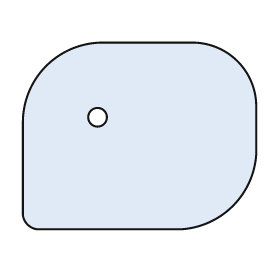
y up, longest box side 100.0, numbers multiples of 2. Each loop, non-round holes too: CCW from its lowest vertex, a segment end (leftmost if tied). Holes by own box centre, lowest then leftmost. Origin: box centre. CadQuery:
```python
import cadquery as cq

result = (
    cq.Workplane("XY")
    .moveTo(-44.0, -40.0)
    .lineTo(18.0, -40.0)
    .threePointArc((40.0, -30.0), (50.0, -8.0))
    .lineTo(50.0, 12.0)
    .threePointArc((42.0, 32.0), (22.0, 40.0))
    .lineTo(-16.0, 40.0)
    .threePointArc((-40.0, 30.0), (-50.0, 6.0))
    .lineTo(-50.0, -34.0)
    .threePointArc((-48.0, -38.0), (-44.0, -40.0))
    .close()
    .moveTo(-18.0, 8.0)
    .circle(4.0)
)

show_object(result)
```